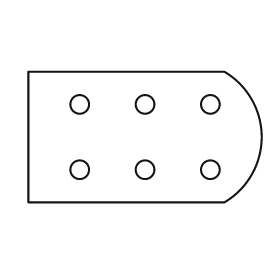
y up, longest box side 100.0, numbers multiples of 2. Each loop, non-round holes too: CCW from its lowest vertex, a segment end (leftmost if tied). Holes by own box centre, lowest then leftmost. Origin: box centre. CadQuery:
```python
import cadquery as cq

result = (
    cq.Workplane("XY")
    .moveTo(-50.0, -28.0)
    .lineTo(34.0, -28.0)
    .threePointArc((50.0, 0.0), (34.0, 28.0))
    .lineTo(-50.0, 28.0)
    .close()
    .moveTo(-28.0, -14.0)
    .circle(4.0)
    .moveTo(0.0, -14.0)
    .circle(4.0)
    .moveTo(28.0, -14.0)
    .circle(4.0)
    .moveTo(-28.0, 14.0)
    .circle(4.0)
    .moveTo(0.0, 14.0)
    .circle(4.0)
    .moveTo(28.0, 14.0)
    .circle(4.0)
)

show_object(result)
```